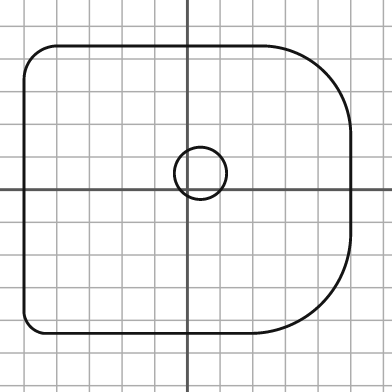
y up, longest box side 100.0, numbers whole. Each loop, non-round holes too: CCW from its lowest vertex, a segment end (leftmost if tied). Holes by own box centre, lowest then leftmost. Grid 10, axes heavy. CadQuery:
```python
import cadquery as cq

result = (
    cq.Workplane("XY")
    .moveTo(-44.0, -44.0)
    .lineTo(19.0, -44.0)
    .threePointArc((41.0, -35.0), (50.0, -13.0))
    .lineTo(50.0, 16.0)
    .threePointArc((42.0, 36.0), (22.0, 44.0))
    .lineTo(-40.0, 44.0)
    .threePointArc((-47.0, 41.0), (-50.0, 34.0))
    .lineTo(-50.0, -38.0)
    .threePointArc((-48.0, -42.0), (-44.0, -44.0))
    .close()
    .moveTo(4.0, 5.0)
    .circle(8.0)
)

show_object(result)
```